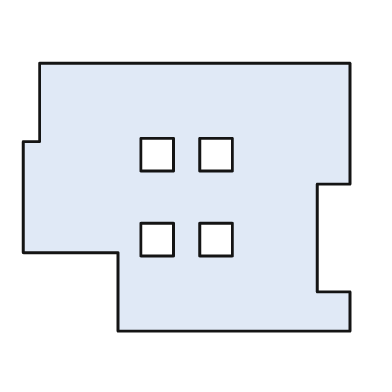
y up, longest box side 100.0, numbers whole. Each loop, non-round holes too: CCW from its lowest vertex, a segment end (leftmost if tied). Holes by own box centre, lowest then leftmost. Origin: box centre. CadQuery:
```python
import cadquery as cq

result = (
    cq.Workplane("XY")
    .moveTo(-21.0, -41.0)
    .lineTo(50.0, -41.0)
    .lineTo(50.0, -29.0)
    .lineTo(40.0, -29.0)
    .lineTo(40.0, 4.0)
    .lineTo(50.0, 4.0)
    .lineTo(50.0, 41.0)
    .lineTo(-45.0, 41.0)
    .lineTo(-45.0, 17.0)
    .lineTo(-50.0, 17.0)
    .lineTo(-50.0, -17.0)
    .lineTo(-21.0, -17.0)
    .close()
    .moveTo(-14.0, -18.0)
    .lineTo(-4.0, -18.0)
    .lineTo(-4.0, -8.0)
    .lineTo(-14.0, -8.0)
    .close()
    .moveTo(4.0, -18.0)
    .lineTo(14.0, -18.0)
    .lineTo(14.0, -8.0)
    .lineTo(4.0, -8.0)
    .close()
    .moveTo(-14.0, 8.0)
    .lineTo(-4.0, 8.0)
    .lineTo(-4.0, 18.0)
    .lineTo(-14.0, 18.0)
    .close()
    .moveTo(4.0, 8.0)
    .lineTo(14.0, 8.0)
    .lineTo(14.0, 18.0)
    .lineTo(4.0, 18.0)
    .close()
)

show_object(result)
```